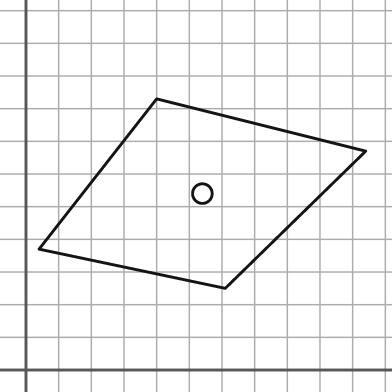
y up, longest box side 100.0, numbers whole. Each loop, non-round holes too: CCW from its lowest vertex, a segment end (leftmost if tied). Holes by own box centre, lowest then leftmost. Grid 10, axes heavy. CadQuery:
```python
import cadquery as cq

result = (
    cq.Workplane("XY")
    .moveTo(61.0, 25.0)
    .lineTo(104.0, 67.0)
    .lineTo(40.0, 83.0)
    .lineTo(4.0, 37.0)
    .close()
    .moveTo(54.0, 54.0)
    .circle(3.0)
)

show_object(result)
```